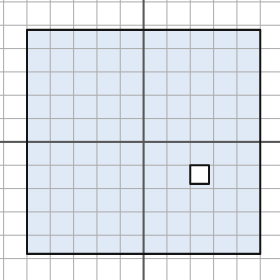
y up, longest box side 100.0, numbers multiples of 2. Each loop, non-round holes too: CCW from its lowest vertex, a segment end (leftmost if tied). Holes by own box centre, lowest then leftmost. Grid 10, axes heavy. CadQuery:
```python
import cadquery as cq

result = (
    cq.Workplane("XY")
    .moveTo(-50.0, -48.0)
    .lineTo(50.0, -48.0)
    .lineTo(50.0, 48.0)
    .lineTo(-50.0, 48.0)
    .close()
    .moveTo(20.0, -18.0)
    .lineTo(28.0, -18.0)
    .lineTo(28.0, -10.0)
    .lineTo(20.0, -10.0)
    .close()
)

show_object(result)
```